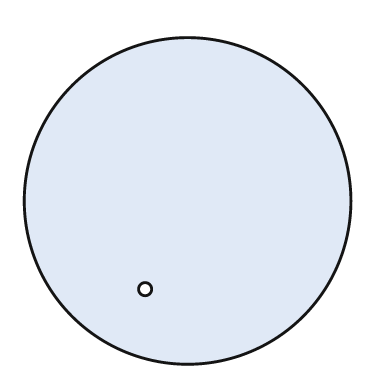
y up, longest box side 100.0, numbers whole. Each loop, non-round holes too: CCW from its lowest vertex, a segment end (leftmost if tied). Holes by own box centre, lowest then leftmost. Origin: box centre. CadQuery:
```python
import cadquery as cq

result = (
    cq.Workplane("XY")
    .moveTo(0.0, 0.0)
    .circle(50.0)
    .moveTo(-13.0, -27.0)
    .circle(2.0)
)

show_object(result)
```